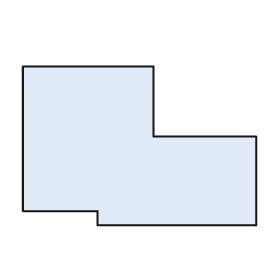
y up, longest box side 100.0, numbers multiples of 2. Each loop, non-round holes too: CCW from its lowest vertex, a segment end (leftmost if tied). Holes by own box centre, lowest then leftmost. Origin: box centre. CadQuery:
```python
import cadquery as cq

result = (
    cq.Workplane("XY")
    .moveTo(-18.0, -34.0)
    .lineTo(50.0, -34.0)
    .lineTo(50.0, 4.0)
    .lineTo(6.0, 4.0)
    .lineTo(6.0, 34.0)
    .lineTo(-50.0, 34.0)
    .lineTo(-50.0, -28.0)
    .lineTo(-18.0, -28.0)
    .close()
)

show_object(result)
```